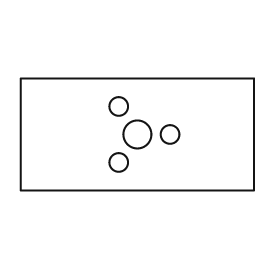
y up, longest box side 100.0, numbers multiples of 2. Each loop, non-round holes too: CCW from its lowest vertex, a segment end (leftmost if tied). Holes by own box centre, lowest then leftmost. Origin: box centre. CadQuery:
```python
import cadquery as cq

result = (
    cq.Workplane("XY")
    .moveTo(-50.0, -24.0)
    .lineTo(50.0, -24.0)
    .lineTo(50.0, 24.0)
    .lineTo(-50.0, 24.0)
    .close()
    .moveTo(-8.0, -12.0)
    .circle(4.0)
    .moveTo(0.0, 0.0)
    .circle(6.0)
    .moveTo(14.0, 0.0)
    .circle(4.0)
    .moveTo(-8.0, 12.0)
    .circle(4.0)
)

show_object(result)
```